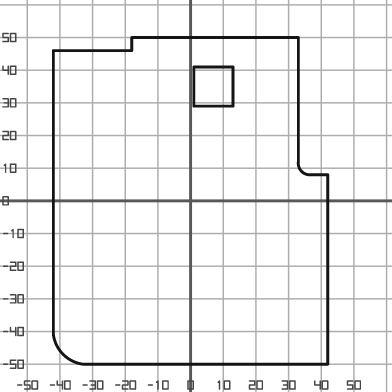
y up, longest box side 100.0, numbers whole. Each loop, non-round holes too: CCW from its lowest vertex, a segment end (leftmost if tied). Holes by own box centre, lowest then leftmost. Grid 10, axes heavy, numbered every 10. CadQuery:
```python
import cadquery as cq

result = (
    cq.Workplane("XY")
    .moveTo(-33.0, -50.0)
    .lineTo(42.0, -50.0)
    .lineTo(42.0, 8.0)
    .lineTo(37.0, 8.0)
    .threePointArc((34.0, 9.0), (33.0, 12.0))
    .lineTo(33.0, 50.0)
    .lineTo(-18.0, 50.0)
    .lineTo(-18.0, 46.0)
    .lineTo(-42.0, 46.0)
    .lineTo(-42.0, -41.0)
    .threePointArc((-39.0, -47.0), (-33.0, -50.0))
    .close()
    .moveTo(1.0, 29.0)
    .lineTo(13.0, 29.0)
    .lineTo(13.0, 41.0)
    .lineTo(1.0, 41.0)
    .close()
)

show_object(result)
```